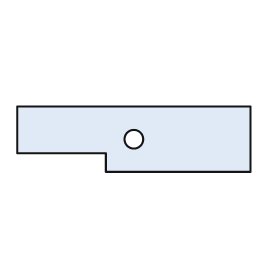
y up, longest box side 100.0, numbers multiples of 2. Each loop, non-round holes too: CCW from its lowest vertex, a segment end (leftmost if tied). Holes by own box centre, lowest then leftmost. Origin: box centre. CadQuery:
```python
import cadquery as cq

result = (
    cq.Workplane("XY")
    .moveTo(-12.0, -14.0)
    .lineTo(50.0, -14.0)
    .lineTo(50.0, 14.0)
    .lineTo(-50.0, 14.0)
    .lineTo(-50.0, -6.0)
    .lineTo(-12.0, -6.0)
    .close()
    .moveTo(0.0, 0.0)
    .circle(4.0)
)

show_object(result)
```